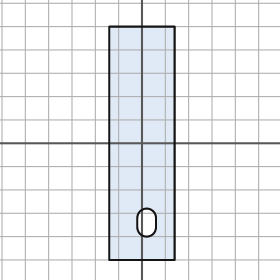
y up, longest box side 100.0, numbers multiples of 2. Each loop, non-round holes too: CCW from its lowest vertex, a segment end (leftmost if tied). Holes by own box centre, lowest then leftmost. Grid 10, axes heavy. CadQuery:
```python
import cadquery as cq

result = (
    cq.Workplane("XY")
    .moveTo(-14.0, -50.0)
    .lineTo(14.0, -50.0)
    .lineTo(14.0, 50.0)
    .lineTo(-14.0, 50.0)
    .close()
    .moveTo(-2.0, -36.0)
    .threePointArc((2.0, -40.0), (6.0, -36.0))
    .lineTo(6.0, -32.0)
    .threePointArc((2.0, -28.0), (-2.0, -32.0))
    .close()
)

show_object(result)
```